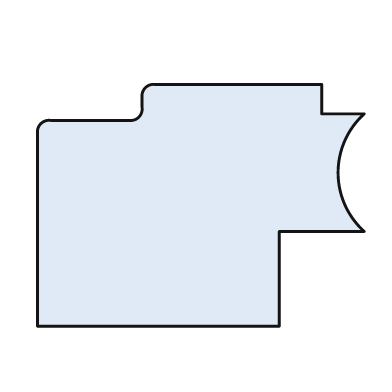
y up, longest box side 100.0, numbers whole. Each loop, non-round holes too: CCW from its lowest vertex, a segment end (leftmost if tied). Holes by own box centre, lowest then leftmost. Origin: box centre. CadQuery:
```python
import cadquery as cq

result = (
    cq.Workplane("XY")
    .moveTo(-50.0, -37.0)
    .lineTo(24.0, -37.0)
    .lineTo(24.0, -8.0)
    .lineTo(50.0, -8.0)
    .threePointArc((42.0, 10.0), (50.0, 28.0))
    .lineTo(37.0, 28.0)
    .lineTo(37.0, 37.0)
    .lineTo(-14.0, 37.0)
    .threePointArc((-17.0, 36.0), (-18.0, 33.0))
    .lineTo(-18.0, 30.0)
    .threePointArc((-19.0, 27.0), (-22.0, 26.0))
    .lineTo(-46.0, 26.0)
    .threePointArc((-49.0, 25.0), (-50.0, 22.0))
    .close()
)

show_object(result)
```